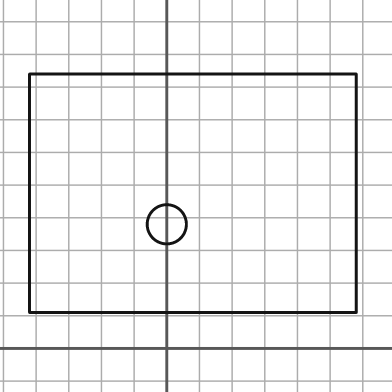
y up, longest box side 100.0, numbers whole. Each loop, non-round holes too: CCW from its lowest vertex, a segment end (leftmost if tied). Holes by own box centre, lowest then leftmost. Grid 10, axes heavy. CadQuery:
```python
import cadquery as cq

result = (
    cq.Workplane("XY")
    .moveTo(-42.0, 11.0)
    .lineTo(58.0, 11.0)
    .lineTo(58.0, 84.0)
    .lineTo(-42.0, 84.0)
    .close()
    .moveTo(0.0, 38.0)
    .circle(6.0)
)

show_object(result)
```